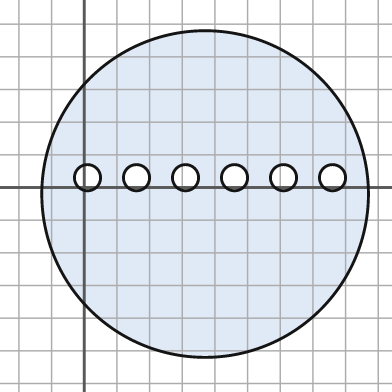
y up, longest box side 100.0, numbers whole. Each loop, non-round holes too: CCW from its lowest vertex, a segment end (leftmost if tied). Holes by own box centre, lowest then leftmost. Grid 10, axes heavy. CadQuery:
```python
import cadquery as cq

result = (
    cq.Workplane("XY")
    .moveTo(37.0, -2.0)
    .circle(50.0)
    .moveTo(1.0, 3.0)
    .circle(4.0)
    .moveTo(16.0, 3.0)
    .circle(4.0)
    .moveTo(31.0, 3.0)
    .circle(4.0)
    .moveTo(46.0, 3.0)
    .circle(4.0)
    .moveTo(61.0, 3.0)
    .circle(4.0)
    .moveTo(76.0, 3.0)
    .circle(4.0)
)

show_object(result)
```